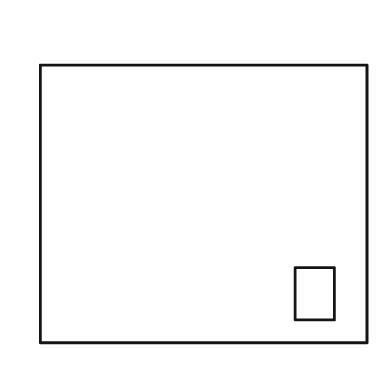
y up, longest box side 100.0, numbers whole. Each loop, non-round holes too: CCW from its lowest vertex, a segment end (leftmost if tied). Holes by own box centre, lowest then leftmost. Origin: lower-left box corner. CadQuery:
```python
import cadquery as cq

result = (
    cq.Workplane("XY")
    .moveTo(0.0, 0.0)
    .lineTo(100.0, 0.0)
    .lineTo(100.0, 85.0)
    .lineTo(0.0, 85.0)
    .close()
    .moveTo(78.0, 7.0)
    .lineTo(90.0, 7.0)
    .lineTo(90.0, 23.0)
    .lineTo(78.0, 23.0)
    .close()
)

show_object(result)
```